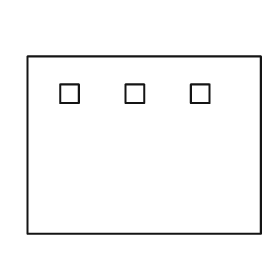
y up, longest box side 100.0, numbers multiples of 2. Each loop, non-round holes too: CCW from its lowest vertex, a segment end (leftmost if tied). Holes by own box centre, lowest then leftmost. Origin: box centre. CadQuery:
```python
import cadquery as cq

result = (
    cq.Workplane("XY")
    .moveTo(-50.0, -38.0)
    .lineTo(50.0, -38.0)
    .lineTo(50.0, 38.0)
    .lineTo(-50.0, 38.0)
    .close()
    .moveTo(-36.0, 18.0)
    .lineTo(-28.0, 18.0)
    .lineTo(-28.0, 26.0)
    .lineTo(-36.0, 26.0)
    .close()
    .moveTo(-8.0, 18.0)
    .lineTo(0.0, 18.0)
    .lineTo(0.0, 26.0)
    .lineTo(-8.0, 26.0)
    .close()
    .moveTo(20.0, 18.0)
    .lineTo(28.0, 18.0)
    .lineTo(28.0, 26.0)
    .lineTo(20.0, 26.0)
    .close()
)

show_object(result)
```